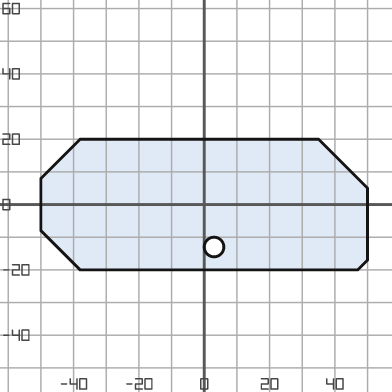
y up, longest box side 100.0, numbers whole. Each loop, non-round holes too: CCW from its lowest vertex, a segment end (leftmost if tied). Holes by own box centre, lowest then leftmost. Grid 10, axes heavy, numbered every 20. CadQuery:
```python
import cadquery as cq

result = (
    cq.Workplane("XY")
    .moveTo(-38.0, -20.0)
    .lineTo(47.0, -20.0)
    .lineTo(50.0, -17.0)
    .lineTo(50.0, 5.0)
    .lineTo(35.0, 20.0)
    .lineTo(-38.0, 20.0)
    .lineTo(-50.0, 8.0)
    .lineTo(-50.0, -8.0)
    .close()
    .moveTo(3.0, -13.0)
    .circle(3.0)
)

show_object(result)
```